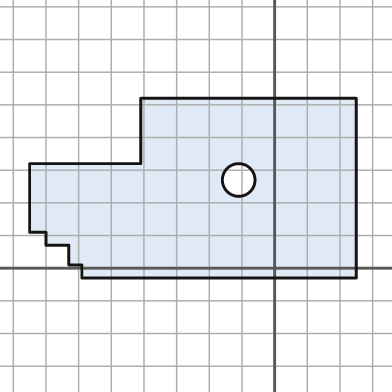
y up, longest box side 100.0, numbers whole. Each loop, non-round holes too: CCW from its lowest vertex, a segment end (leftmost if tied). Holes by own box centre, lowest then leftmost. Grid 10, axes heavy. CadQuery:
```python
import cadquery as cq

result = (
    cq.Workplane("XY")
    .moveTo(-59.0, -3.0)
    .lineTo(25.0, -3.0)
    .lineTo(25.0, 52.0)
    .lineTo(-41.0, 52.0)
    .lineTo(-41.0, 32.0)
    .lineTo(-75.0, 32.0)
    .lineTo(-75.0, 11.0)
    .lineTo(-70.0, 11.0)
    .lineTo(-70.0, 7.0)
    .lineTo(-63.0, 7.0)
    .lineTo(-63.0, 1.0)
    .lineTo(-59.0, 1.0)
    .close()
    .moveTo(-11.0, 27.0)
    .circle(5.0)
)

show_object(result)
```